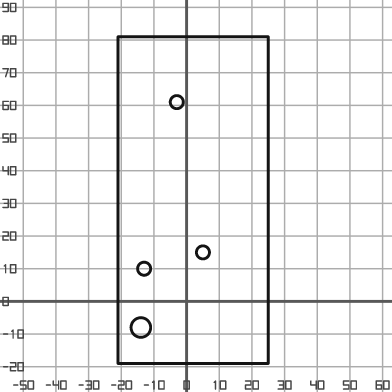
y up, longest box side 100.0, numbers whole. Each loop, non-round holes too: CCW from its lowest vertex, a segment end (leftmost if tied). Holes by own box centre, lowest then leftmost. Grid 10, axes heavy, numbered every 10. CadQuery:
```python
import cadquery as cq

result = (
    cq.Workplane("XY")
    .moveTo(-21.0, -19.0)
    .lineTo(25.0, -19.0)
    .lineTo(25.0, 81.0)
    .lineTo(-21.0, 81.0)
    .close()
    .moveTo(-14.0, -8.0)
    .circle(3.0)
    .moveTo(-13.0, 10.0)
    .circle(2.0)
    .moveTo(5.0, 15.0)
    .circle(2.0)
    .moveTo(-3.0, 61.0)
    .circle(2.0)
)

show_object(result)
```